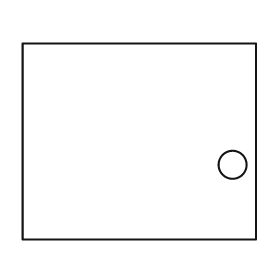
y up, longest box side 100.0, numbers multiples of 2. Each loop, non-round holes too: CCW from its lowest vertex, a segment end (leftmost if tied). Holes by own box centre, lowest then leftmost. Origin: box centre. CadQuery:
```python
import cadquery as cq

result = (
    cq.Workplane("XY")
    .moveTo(-50.0, -42.0)
    .lineTo(50.0, -42.0)
    .lineTo(50.0, 42.0)
    .lineTo(-50.0, 42.0)
    .close()
    .moveTo(40.0, -10.0)
    .circle(6.0)
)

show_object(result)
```